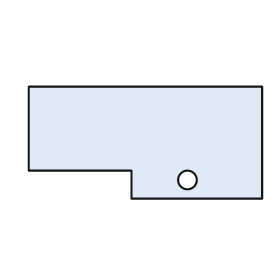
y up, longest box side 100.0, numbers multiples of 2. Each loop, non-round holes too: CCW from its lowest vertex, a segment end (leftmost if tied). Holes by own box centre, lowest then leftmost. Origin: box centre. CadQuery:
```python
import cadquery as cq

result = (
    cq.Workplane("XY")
    .moveTo(-6.0, -24.0)
    .lineTo(50.0, -24.0)
    .lineTo(50.0, 24.0)
    .lineTo(-50.0, 24.0)
    .lineTo(-50.0, -12.0)
    .lineTo(-6.0, -12.0)
    .close()
    .moveTo(18.0, -16.0)
    .circle(4.0)
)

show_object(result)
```